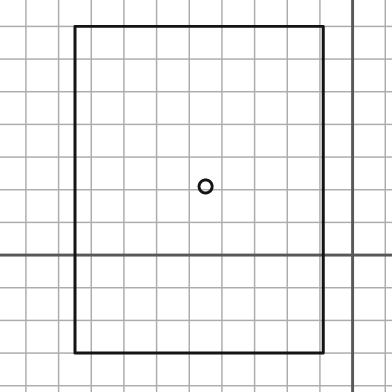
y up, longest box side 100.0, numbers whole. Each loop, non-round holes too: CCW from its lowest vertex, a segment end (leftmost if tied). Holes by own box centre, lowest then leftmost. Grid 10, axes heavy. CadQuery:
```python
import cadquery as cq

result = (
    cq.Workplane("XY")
    .moveTo(-85.0, -30.0)
    .lineTo(-9.0, -30.0)
    .lineTo(-9.0, 70.0)
    .lineTo(-85.0, 70.0)
    .close()
    .moveTo(-45.0, 21.0)
    .circle(2.0)
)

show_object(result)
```